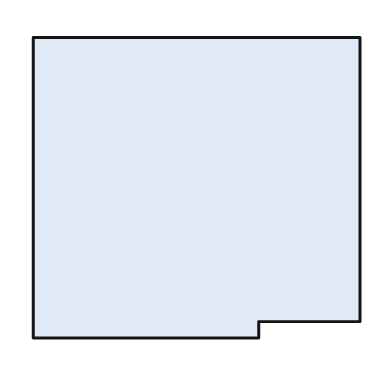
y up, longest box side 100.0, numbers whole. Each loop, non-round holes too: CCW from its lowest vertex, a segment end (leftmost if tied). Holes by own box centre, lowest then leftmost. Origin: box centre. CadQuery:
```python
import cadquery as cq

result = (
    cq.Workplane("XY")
    .moveTo(-50.0, -46.0)
    .lineTo(19.0, -46.0)
    .lineTo(19.0, -41.0)
    .lineTo(50.0, -41.0)
    .lineTo(50.0, 46.0)
    .lineTo(-50.0, 46.0)
    .close()
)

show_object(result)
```